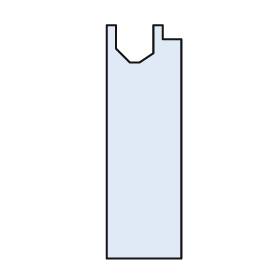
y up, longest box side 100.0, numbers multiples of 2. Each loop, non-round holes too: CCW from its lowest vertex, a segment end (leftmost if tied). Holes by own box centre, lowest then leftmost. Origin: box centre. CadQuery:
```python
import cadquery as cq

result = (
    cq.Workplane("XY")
    .moveTo(-16.0, -50.0)
    .lineTo(16.0, -50.0)
    .lineTo(16.0, 44.0)
    .lineTo(8.0, 44.0)
    .lineTo(8.0, 50.0)
    .lineTo(4.0, 50.0)
    .lineTo(4.0, 38.0)
    .lineTo(-2.0, 34.0)
    .lineTo(-6.0, 34.0)
    .lineTo(-12.0, 40.0)
    .lineTo(-12.0, 50.0)
    .lineTo(-16.0, 50.0)
    .close()
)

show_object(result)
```